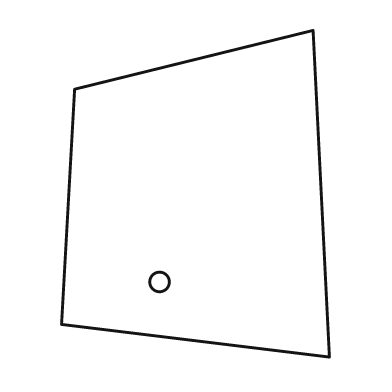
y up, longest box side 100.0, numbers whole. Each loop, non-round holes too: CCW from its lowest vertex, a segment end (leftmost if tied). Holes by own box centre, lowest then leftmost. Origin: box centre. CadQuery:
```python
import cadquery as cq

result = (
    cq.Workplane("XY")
    .moveTo(41.0, -50.0)
    .lineTo(36.0, 50.0)
    .lineTo(-37.0, 32.0)
    .lineTo(-41.0, -40.0)
    .close()
    .moveTo(-11.0, -27.0)
    .circle(3.0)
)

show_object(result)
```